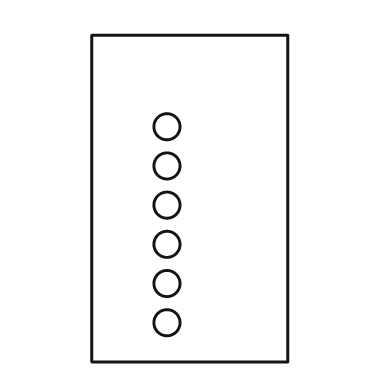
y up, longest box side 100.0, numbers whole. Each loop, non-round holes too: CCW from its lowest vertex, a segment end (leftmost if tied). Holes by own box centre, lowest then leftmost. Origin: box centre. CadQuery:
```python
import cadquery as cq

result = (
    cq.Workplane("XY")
    .moveTo(-30.0, -50.0)
    .lineTo(30.0, -50.0)
    .lineTo(30.0, 50.0)
    .lineTo(-30.0, 50.0)
    .close()
    .moveTo(-7.0, -38.0)
    .circle(4.0)
    .moveTo(-7.0, -26.0)
    .circle(4.0)
    .moveTo(-7.0, -14.0)
    .circle(4.0)
    .moveTo(-7.0, -2.0)
    .circle(4.0)
    .moveTo(-7.0, 10.0)
    .circle(4.0)
    .moveTo(-7.0, 22.0)
    .circle(4.0)
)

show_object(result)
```